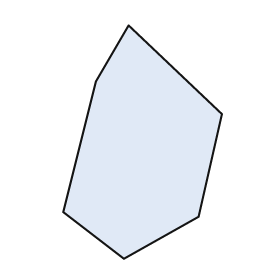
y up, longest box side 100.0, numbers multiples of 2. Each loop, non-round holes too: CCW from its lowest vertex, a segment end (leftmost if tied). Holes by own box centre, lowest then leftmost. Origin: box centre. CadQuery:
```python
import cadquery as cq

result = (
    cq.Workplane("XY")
    .moveTo(-8.0, -50.0)
    .lineTo(24.0, -32.0)
    .lineTo(34.0, 12.0)
    .lineTo(-6.0, 50.0)
    .lineTo(-20.0, 26.0)
    .lineTo(-34.0, -30.0)
    .close()
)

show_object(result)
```